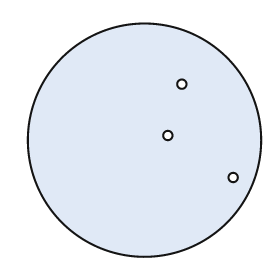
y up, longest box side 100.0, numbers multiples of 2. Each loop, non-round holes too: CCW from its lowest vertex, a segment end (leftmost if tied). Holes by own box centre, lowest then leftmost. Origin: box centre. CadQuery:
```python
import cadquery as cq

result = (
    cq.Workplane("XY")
    .moveTo(0.0, 0.0)
    .circle(50.0)
    .moveTo(38.0, -16.0)
    .circle(2.0)
    .moveTo(10.0, 2.0)
    .circle(2.0)
    .moveTo(16.0, 24.0)
    .circle(2.0)
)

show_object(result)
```